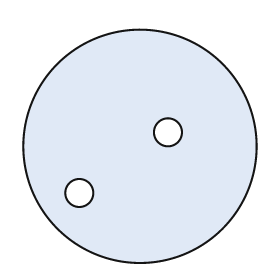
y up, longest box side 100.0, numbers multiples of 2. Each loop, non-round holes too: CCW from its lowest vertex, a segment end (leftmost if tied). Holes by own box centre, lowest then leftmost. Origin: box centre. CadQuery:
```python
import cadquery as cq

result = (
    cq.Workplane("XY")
    .moveTo(0.0, 0.0)
    .circle(50.0)
    .moveTo(-26.0, -20.0)
    .circle(6.0)
    .moveTo(12.0, 6.0)
    .circle(6.0)
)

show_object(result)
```